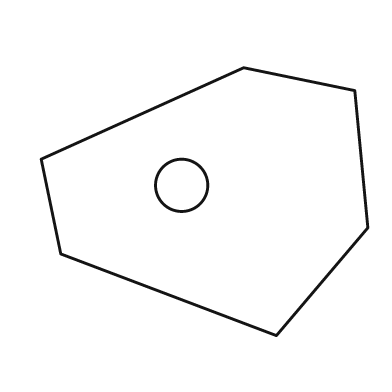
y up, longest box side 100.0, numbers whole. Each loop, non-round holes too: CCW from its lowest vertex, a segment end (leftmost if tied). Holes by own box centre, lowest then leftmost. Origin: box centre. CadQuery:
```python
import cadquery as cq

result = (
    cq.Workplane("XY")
    .moveTo(22.0, -41.0)
    .lineTo(50.0, -8.0)
    .lineTo(46.0, 34.0)
    .lineTo(12.0, 41.0)
    .lineTo(-50.0, 13.0)
    .lineTo(-44.0, -16.0)
    .close()
    .moveTo(-7.0, 5.0)
    .circle(8.0)
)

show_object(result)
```